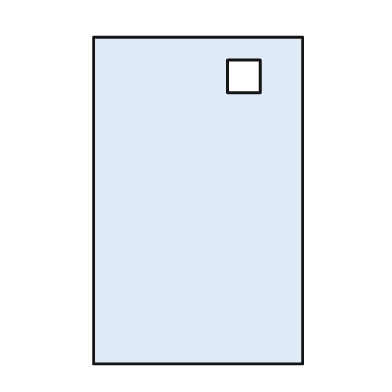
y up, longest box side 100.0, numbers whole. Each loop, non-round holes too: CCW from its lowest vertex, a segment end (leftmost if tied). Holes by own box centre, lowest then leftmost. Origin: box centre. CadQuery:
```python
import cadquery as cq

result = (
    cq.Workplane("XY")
    .moveTo(-32.0, -50.0)
    .lineTo(32.0, -50.0)
    .lineTo(32.0, 50.0)
    .lineTo(-32.0, 50.0)
    .close()
    .moveTo(9.0, 33.0)
    .lineTo(19.0, 33.0)
    .lineTo(19.0, 43.0)
    .lineTo(9.0, 43.0)
    .close()
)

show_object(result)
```